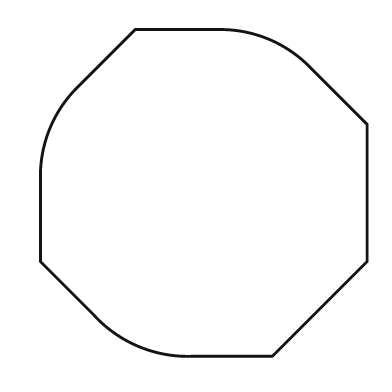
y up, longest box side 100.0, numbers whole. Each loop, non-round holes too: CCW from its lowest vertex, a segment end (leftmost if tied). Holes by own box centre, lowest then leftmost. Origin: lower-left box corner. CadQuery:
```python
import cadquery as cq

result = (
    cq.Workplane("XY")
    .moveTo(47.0, 0.0)
    .lineTo(71.0, 0.0)
    .lineTo(100.0, 29.0)
    .lineTo(100.0, 71.0)
    .lineTo(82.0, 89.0)
    .threePointArc((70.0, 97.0), (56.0, 100.0))
    .lineTo(29.0, 100.0)
    .lineTo(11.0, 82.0)
    .threePointArc((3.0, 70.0), (0.0, 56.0))
    .lineTo(0.0, 29.0)
    .lineTo(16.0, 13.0)
    .threePointArc((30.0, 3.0), (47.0, 0.0))
    .close()
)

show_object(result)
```